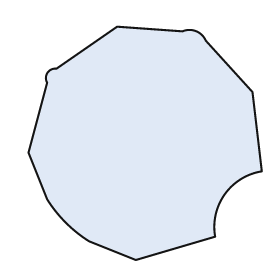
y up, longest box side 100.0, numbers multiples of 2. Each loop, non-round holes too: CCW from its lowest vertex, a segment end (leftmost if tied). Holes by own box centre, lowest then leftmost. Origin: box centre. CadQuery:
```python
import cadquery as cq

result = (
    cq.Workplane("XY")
    .moveTo(-4.0, -50.0)
    .lineTo(30.0, -40.0)
    .threePointArc((34.0, -22.0), (50.0, -12.0))
    .lineTo(46.0, 22.0)
    .lineTo(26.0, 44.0)
    .threePointArc((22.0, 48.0), (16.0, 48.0))
    .lineTo(-12.0, 50.0)
    .lineTo(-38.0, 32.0)
    .threePointArc((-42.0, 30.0), (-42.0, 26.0))
    .lineTo(-50.0, -4.0)
    .lineTo(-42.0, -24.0)
    .threePointArc((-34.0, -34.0), (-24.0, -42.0))
    .close()
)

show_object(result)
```